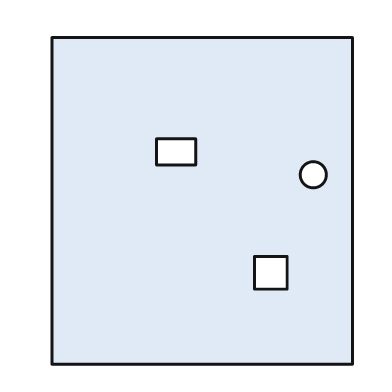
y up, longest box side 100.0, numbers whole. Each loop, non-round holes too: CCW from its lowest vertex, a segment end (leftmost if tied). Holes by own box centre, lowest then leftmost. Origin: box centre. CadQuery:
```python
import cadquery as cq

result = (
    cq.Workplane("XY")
    .moveTo(-46.0, -50.0)
    .lineTo(46.0, -50.0)
    .lineTo(46.0, 50.0)
    .lineTo(-46.0, 50.0)
    .close()
    .moveTo(16.0, -27.0)
    .lineTo(26.0, -27.0)
    .lineTo(26.0, -17.0)
    .lineTo(16.0, -17.0)
    .close()
    .moveTo(34.0, 8.0)
    .circle(4.0)
    .moveTo(-14.0, 11.0)
    .lineTo(-2.0, 11.0)
    .lineTo(-2.0, 19.0)
    .lineTo(-14.0, 19.0)
    .close()
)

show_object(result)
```